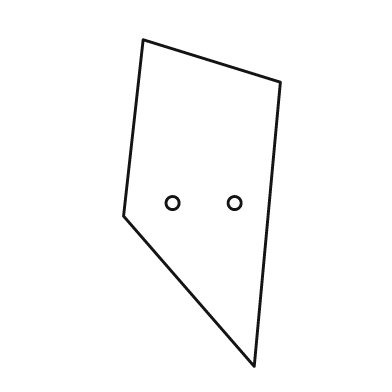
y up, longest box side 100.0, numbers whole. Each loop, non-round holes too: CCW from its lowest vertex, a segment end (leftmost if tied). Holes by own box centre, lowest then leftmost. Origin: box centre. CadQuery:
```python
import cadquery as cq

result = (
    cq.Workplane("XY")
    .moveTo(16.0, -50.0)
    .lineTo(24.0, 37.0)
    .lineTo(-18.0, 50.0)
    .lineTo(-24.0, -4.0)
    .close()
    .moveTo(-9.0, 0.0)
    .circle(2.0)
    .moveTo(10.0, 0.0)
    .circle(2.0)
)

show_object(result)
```